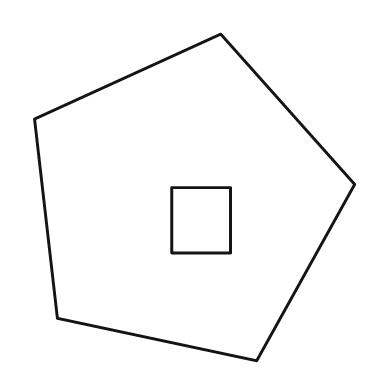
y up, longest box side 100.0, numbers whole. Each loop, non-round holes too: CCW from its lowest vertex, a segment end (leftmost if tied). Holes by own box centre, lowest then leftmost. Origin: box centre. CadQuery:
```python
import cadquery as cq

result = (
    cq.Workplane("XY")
    .moveTo(19.0, -50.0)
    .lineTo(49.0, 4.0)
    .lineTo(8.0, 50.0)
    .lineTo(-49.0, 24.0)
    .lineTo(-42.0, -37.0)
    .close()
    .moveTo(-7.0, -17.0)
    .lineTo(11.0, -17.0)
    .lineTo(11.0, 3.0)
    .lineTo(-7.0, 3.0)
    .close()
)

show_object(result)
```